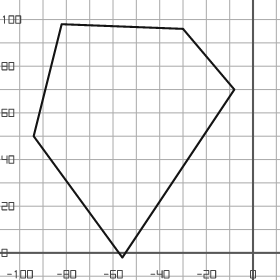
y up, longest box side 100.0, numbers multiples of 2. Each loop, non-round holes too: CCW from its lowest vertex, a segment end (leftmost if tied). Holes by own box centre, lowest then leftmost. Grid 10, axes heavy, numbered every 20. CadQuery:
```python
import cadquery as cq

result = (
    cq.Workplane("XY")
    .moveTo(-56.0, -2.0)
    .lineTo(-8.0, 70.0)
    .lineTo(-30.0, 96.0)
    .lineTo(-82.0, 98.0)
    .lineTo(-94.0, 50.0)
    .close()
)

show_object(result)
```